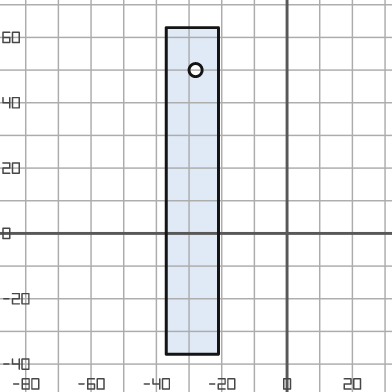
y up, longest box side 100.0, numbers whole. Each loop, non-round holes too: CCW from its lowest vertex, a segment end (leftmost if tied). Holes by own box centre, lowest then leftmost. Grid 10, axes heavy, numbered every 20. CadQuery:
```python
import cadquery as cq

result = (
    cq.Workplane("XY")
    .moveTo(-37.0, -37.0)
    .lineTo(-21.0, -37.0)
    .lineTo(-21.0, 63.0)
    .lineTo(-37.0, 63.0)
    .close()
    .moveTo(-28.0, 50.0)
    .circle(2.0)
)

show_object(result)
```